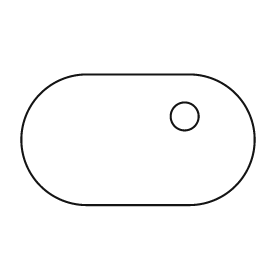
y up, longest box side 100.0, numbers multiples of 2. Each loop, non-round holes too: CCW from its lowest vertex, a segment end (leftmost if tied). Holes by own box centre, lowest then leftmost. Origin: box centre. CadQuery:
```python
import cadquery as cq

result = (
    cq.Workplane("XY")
    .moveTo(-22.0, -28.0)
    .lineTo(22.0, -28.0)
    .threePointArc((50.0, 0.0), (22.0, 28.0))
    .lineTo(-22.0, 28.0)
    .threePointArc((-50.0, 0.0), (-22.0, -28.0))
    .close()
    .moveTo(20.0, 10.0)
    .circle(6.0)
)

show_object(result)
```